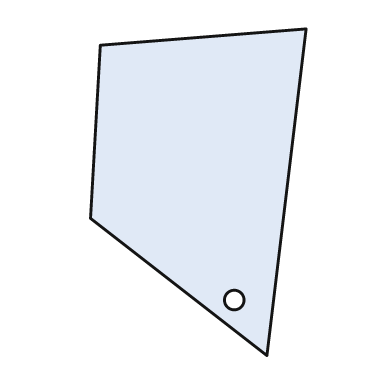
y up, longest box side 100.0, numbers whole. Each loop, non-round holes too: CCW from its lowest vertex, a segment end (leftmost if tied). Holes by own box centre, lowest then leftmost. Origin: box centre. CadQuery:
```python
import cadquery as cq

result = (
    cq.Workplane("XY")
    .moveTo(21.0, -50.0)
    .lineTo(33.0, 50.0)
    .lineTo(-30.0, 45.0)
    .lineTo(-33.0, -8.0)
    .close()
    .moveTo(11.0, -33.0)
    .circle(3.0)
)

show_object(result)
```